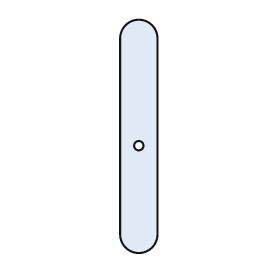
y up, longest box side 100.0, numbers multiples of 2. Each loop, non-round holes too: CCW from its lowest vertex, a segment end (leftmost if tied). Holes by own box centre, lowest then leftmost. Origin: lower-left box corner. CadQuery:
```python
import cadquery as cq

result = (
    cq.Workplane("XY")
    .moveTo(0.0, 8.0)
    .threePointArc((8.0, 0.0), (16.0, 8.0))
    .lineTo(16.0, 92.0)
    .threePointArc((8.0, 100.0), (0.0, 92.0))
    .close()
    .moveTo(8.0, 46.0)
    .circle(2.0)
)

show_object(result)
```